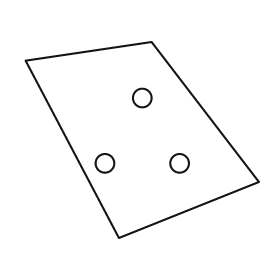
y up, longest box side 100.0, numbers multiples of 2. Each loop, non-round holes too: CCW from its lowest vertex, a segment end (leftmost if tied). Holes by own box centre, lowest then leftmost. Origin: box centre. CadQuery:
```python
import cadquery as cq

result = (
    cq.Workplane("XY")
    .moveTo(-10.0, -42.0)
    .lineTo(50.0, -18.0)
    .lineTo(4.0, 42.0)
    .lineTo(-50.0, 34.0)
    .close()
    .moveTo(-16.0, -10.0)
    .circle(4.0)
    .moveTo(16.0, -10.0)
    .circle(4.0)
    .moveTo(0.0, 18.0)
    .circle(4.0)
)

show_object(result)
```